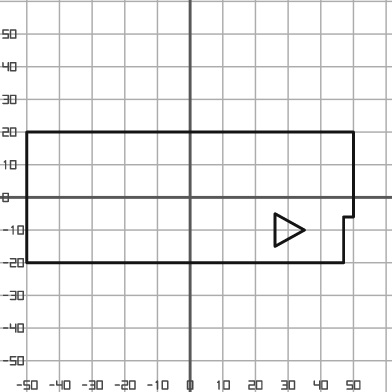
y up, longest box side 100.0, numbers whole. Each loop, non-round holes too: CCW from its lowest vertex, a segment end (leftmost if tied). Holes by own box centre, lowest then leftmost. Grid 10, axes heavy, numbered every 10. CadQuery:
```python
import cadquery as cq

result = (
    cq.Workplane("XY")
    .moveTo(-50.0, -20.0)
    .lineTo(47.0, -20.0)
    .lineTo(47.0, -6.0)
    .lineTo(50.0, -6.0)
    .lineTo(50.0, 20.0)
    .lineTo(-50.0, 20.0)
    .close()
    .moveTo(26.0, -15.0)
    .lineTo(35.0, -10.0)
    .lineTo(26.0, -5.0)
    .close()
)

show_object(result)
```